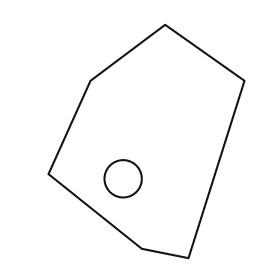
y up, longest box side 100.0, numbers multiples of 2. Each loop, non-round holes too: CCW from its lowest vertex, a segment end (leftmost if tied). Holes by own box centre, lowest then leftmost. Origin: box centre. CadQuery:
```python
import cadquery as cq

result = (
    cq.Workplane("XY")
    .moveTo(18.0, -50.0)
    .lineTo(42.0, 26.0)
    .lineTo(8.0, 50.0)
    .lineTo(-24.0, 26.0)
    .lineTo(-42.0, -14.0)
    .lineTo(-2.0, -46.0)
    .close()
    .moveTo(-10.0, -16.0)
    .circle(8.0)
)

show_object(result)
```